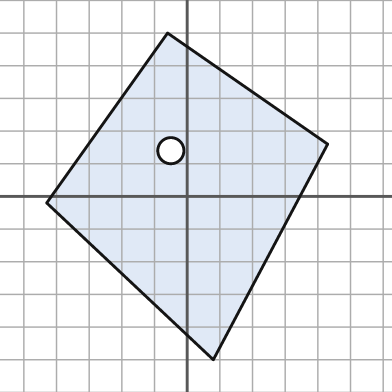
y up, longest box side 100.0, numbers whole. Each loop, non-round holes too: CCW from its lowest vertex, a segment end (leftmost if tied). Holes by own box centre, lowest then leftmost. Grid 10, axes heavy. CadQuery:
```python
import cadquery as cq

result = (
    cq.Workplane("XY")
    .moveTo(8.0, -50.0)
    .lineTo(43.0, 16.0)
    .lineTo(-6.0, 50.0)
    .lineTo(-43.0, -2.0)
    .close()
    .moveTo(-5.0, 14.0)
    .circle(4.0)
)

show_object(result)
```